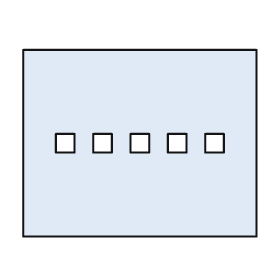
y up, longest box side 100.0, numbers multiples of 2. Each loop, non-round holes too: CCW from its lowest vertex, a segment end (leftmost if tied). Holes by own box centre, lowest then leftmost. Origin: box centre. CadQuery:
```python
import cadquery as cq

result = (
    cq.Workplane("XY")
    .moveTo(-50.0, -40.0)
    .lineTo(50.0, -40.0)
    .lineTo(50.0, 40.0)
    .lineTo(-50.0, 40.0)
    .close()
    .moveTo(-36.0, -4.0)
    .lineTo(-28.0, -4.0)
    .lineTo(-28.0, 4.0)
    .lineTo(-36.0, 4.0)
    .close()
    .moveTo(-20.0, -4.0)
    .lineTo(-12.0, -4.0)
    .lineTo(-12.0, 4.0)
    .lineTo(-20.0, 4.0)
    .close()
    .moveTo(-4.0, -4.0)
    .lineTo(4.0, -4.0)
    .lineTo(4.0, 4.0)
    .lineTo(-4.0, 4.0)
    .close()
    .moveTo(12.0, -4.0)
    .lineTo(20.0, -4.0)
    .lineTo(20.0, 4.0)
    .lineTo(12.0, 4.0)
    .close()
    .moveTo(28.0, -4.0)
    .lineTo(36.0, -4.0)
    .lineTo(36.0, 4.0)
    .lineTo(28.0, 4.0)
    .close()
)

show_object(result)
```